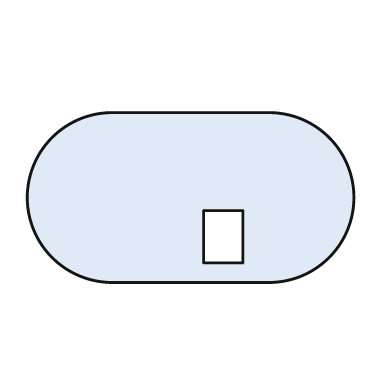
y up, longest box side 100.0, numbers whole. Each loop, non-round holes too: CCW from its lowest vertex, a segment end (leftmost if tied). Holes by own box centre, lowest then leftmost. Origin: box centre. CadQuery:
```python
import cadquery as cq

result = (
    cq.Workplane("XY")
    .moveTo(-24.0, -26.0)
    .lineTo(24.0, -26.0)
    .threePointArc((50.0, 0.0), (24.0, 26.0))
    .lineTo(-24.0, 26.0)
    .threePointArc((-50.0, 0.0), (-24.0, -26.0))
    .close()
    .moveTo(4.0, -20.0)
    .lineTo(16.0, -20.0)
    .lineTo(16.0, -4.0)
    .lineTo(4.0, -4.0)
    .close()
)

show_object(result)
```